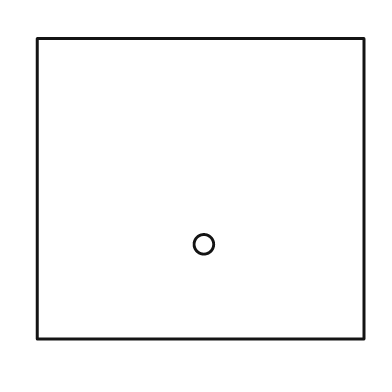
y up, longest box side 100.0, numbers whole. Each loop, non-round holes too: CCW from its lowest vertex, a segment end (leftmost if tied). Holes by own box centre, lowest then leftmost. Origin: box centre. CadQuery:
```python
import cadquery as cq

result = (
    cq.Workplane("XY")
    .moveTo(-50.0, -46.0)
    .lineTo(50.0, -46.0)
    .lineTo(50.0, 46.0)
    .lineTo(-50.0, 46.0)
    .close()
    .moveTo(1.0, -17.0)
    .circle(3.0)
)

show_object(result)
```